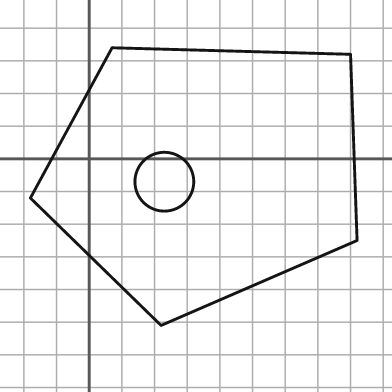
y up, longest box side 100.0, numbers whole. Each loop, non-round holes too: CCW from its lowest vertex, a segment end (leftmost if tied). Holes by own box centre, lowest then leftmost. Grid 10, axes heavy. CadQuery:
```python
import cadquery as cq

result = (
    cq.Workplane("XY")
    .moveTo(22.0, -51.0)
    .lineTo(82.0, -25.0)
    .lineTo(80.0, 32.0)
    .lineTo(7.0, 34.0)
    .lineTo(-18.0, -12.0)
    .close()
    .moveTo(23.0, -7.0)
    .circle(9.0)
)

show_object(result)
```